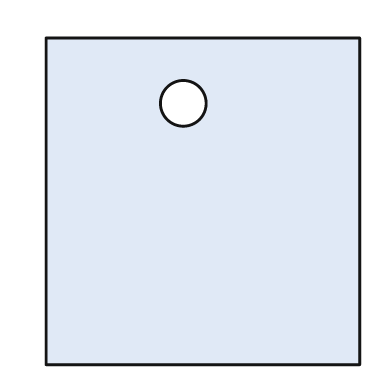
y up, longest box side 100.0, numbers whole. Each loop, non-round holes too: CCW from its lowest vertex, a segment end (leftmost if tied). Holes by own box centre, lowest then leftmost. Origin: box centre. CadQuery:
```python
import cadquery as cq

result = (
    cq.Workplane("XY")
    .moveTo(-48.0, -50.0)
    .lineTo(48.0, -50.0)
    .lineTo(48.0, 50.0)
    .lineTo(-48.0, 50.0)
    .close()
    .moveTo(-6.0, 30.0)
    .circle(7.0)
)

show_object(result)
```